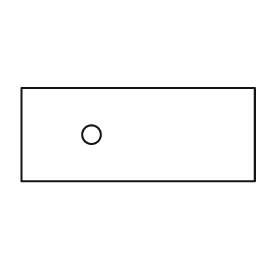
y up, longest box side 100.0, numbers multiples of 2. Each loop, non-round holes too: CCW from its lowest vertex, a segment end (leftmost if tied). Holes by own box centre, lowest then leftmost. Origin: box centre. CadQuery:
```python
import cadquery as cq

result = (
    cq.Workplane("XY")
    .moveTo(-50.0, -20.0)
    .lineTo(50.0, -20.0)
    .lineTo(50.0, 20.0)
    .lineTo(-50.0, 20.0)
    .close()
    .moveTo(-20.0, 0.0)
    .circle(4.0)
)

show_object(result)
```